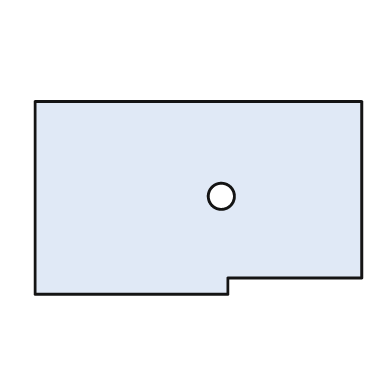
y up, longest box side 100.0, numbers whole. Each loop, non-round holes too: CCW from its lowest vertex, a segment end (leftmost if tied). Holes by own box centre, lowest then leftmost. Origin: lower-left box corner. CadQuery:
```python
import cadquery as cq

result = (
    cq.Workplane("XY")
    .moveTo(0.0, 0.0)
    .lineTo(59.0, 0.0)
    .lineTo(59.0, 5.0)
    .lineTo(100.0, 5.0)
    .lineTo(100.0, 59.0)
    .lineTo(0.0, 59.0)
    .close()
    .moveTo(57.0, 30.0)
    .circle(4.0)
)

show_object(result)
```